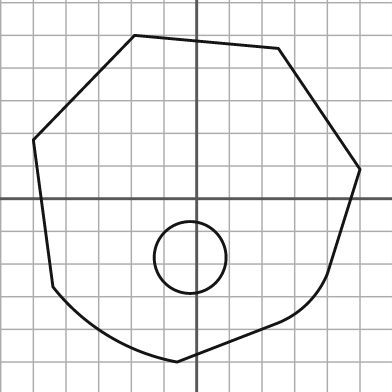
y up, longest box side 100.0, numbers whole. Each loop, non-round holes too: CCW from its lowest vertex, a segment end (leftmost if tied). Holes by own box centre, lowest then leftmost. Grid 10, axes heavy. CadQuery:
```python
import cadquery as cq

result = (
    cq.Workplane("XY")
    .moveTo(-6.0, -50.0)
    .lineTo(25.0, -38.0)
    .threePointArc((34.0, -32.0), (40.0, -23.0))
    .lineTo(50.0, 9.0)
    .lineTo(25.0, 46.0)
    .lineTo(-19.0, 50.0)
    .lineTo(-50.0, 18.0)
    .lineTo(-44.0, -27.0)
    .threePointArc((-27.0, -42.0), (-6.0, -50.0))
    .close()
    .moveTo(-2.0, -18.0)
    .circle(11.0)
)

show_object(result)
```